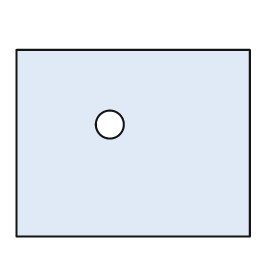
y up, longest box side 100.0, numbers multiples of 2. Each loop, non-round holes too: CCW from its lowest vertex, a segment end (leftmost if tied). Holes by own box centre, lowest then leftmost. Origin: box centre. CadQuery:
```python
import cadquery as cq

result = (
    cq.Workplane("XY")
    .moveTo(-50.0, -40.0)
    .lineTo(50.0, -40.0)
    .lineTo(50.0, 40.0)
    .lineTo(-50.0, 40.0)
    .close()
    .moveTo(-10.0, 8.0)
    .circle(6.0)
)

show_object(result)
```